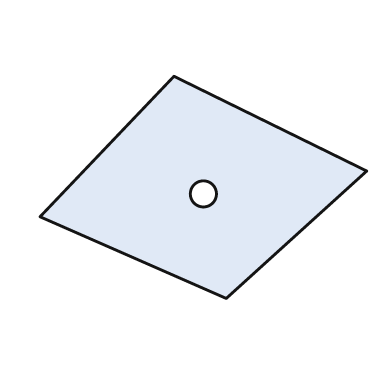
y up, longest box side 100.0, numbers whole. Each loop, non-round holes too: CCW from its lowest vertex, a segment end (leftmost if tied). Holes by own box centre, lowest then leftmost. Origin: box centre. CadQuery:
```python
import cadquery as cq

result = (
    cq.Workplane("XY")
    .moveTo(7.0, -34.0)
    .lineTo(50.0, 5.0)
    .lineTo(-9.0, 34.0)
    .lineTo(-50.0, -9.0)
    .close()
    .moveTo(0.0, -2.0)
    .circle(4.0)
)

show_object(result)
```